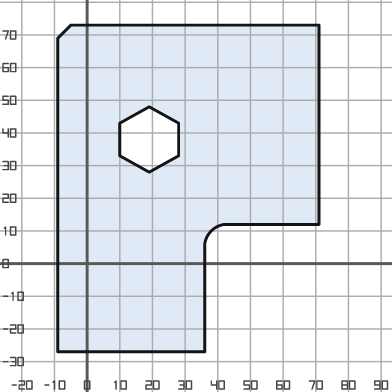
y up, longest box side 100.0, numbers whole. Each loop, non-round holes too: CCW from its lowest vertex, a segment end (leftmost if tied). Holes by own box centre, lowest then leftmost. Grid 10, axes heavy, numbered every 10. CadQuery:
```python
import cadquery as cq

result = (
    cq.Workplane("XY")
    .moveTo(-9.0, -27.0)
    .lineTo(36.0, -27.0)
    .lineTo(36.0, 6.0)
    .threePointArc((38.0, 10.0), (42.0, 12.0))
    .lineTo(71.0, 12.0)
    .lineTo(71.0, 73.0)
    .lineTo(-5.0, 73.0)
    .lineTo(-9.0, 69.0)
    .close()
    .moveTo(19.0, 28.0)
    .lineTo(28.0, 33.0)
    .lineTo(28.0, 43.0)
    .lineTo(19.0, 48.0)
    .lineTo(10.0, 43.0)
    .lineTo(10.0, 33.0)
    .close()
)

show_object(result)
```